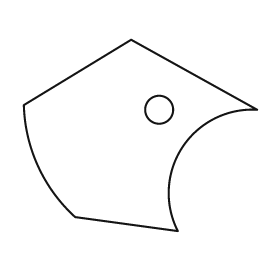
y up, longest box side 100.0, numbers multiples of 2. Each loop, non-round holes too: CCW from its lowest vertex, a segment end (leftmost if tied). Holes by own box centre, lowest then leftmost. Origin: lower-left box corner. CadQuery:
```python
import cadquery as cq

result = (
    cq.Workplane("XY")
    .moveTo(66.0, 0.0)
    .threePointArc((68.0, 36.0), (100.0, 52.0))
    .lineTo(46.0, 82.0)
    .lineTo(0.0, 54.0)
    .threePointArc((6.0, 28.0), (22.0, 6.0))
    .close()
    .moveTo(58.0, 52.0)
    .circle(6.0)
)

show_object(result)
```